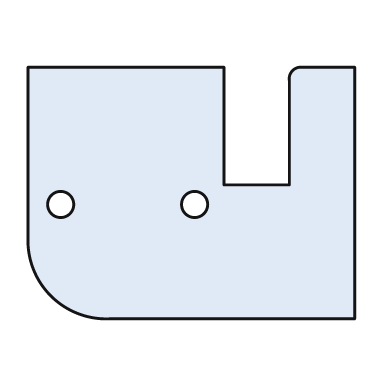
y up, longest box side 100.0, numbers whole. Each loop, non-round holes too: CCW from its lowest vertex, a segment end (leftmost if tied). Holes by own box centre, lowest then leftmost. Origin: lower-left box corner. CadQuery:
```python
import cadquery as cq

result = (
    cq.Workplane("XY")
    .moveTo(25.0, 0.0)
    .lineTo(100.0, 0.0)
    .lineTo(100.0, 77.0)
    .lineTo(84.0, 77.0)
    .threePointArc((81.0, 76.0), (80.0, 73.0))
    .lineTo(80.0, 41.0)
    .lineTo(60.0, 41.0)
    .lineTo(60.0, 77.0)
    .lineTo(0.0, 77.0)
    .lineTo(0.0, 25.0)
    .threePointArc((7.0, 7.0), (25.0, 0.0))
    .close()
    .moveTo(10.0, 35.0)
    .circle(4.0)
    .moveTo(51.0, 35.0)
    .circle(4.0)
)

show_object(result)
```